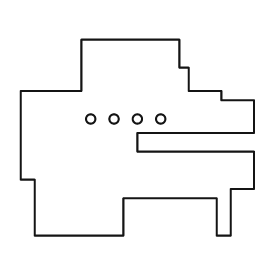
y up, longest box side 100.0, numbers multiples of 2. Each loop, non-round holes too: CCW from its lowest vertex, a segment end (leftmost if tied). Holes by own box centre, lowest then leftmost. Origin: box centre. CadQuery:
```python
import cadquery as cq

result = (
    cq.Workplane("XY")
    .moveTo(-44.0, -42.0)
    .lineTo(-6.0, -42.0)
    .lineTo(-6.0, -26.0)
    .lineTo(34.0, -26.0)
    .lineTo(34.0, -42.0)
    .lineTo(40.0, -42.0)
    .lineTo(40.0, -22.0)
    .lineTo(50.0, -22.0)
    .lineTo(50.0, -6.0)
    .lineTo(0.0, -6.0)
    .lineTo(0.0, 2.0)
    .lineTo(50.0, 2.0)
    .lineTo(50.0, 16.0)
    .lineTo(36.0, 16.0)
    .lineTo(36.0, 20.0)
    .lineTo(22.0, 20.0)
    .lineTo(22.0, 30.0)
    .lineTo(18.0, 30.0)
    .lineTo(18.0, 42.0)
    .lineTo(-24.0, 42.0)
    .lineTo(-24.0, 20.0)
    .lineTo(-50.0, 20.0)
    .lineTo(-50.0, -18.0)
    .lineTo(-44.0, -18.0)
    .close()
    .moveTo(-20.0, 8.0)
    .circle(2.0)
    .moveTo(-10.0, 8.0)
    .circle(2.0)
    .moveTo(0.0, 8.0)
    .circle(2.0)
    .moveTo(10.0, 8.0)
    .circle(2.0)
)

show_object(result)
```